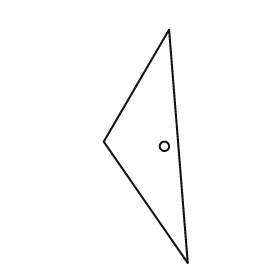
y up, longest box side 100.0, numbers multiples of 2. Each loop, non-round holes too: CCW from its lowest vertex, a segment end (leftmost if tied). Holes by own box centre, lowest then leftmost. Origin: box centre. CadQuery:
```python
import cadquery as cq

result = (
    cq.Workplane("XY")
    .moveTo(18.0, -50.0)
    .lineTo(10.0, 50.0)
    .lineTo(-18.0, 2.0)
    .close()
    .moveTo(8.0, 0.0)
    .circle(2.0)
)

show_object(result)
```